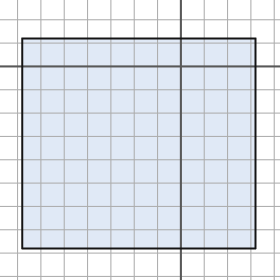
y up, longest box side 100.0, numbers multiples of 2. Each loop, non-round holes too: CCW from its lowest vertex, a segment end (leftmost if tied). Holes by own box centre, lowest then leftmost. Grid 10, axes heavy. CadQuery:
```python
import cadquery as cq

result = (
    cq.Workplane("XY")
    .moveTo(-68.0, -78.0)
    .lineTo(32.0, -78.0)
    .lineTo(32.0, 12.0)
    .lineTo(-68.0, 12.0)
    .close()
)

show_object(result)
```